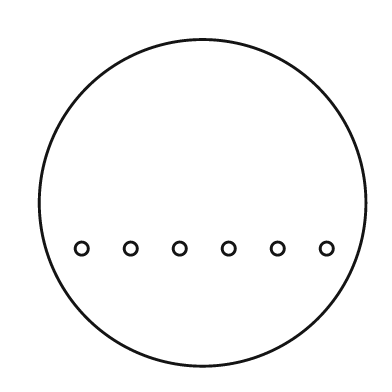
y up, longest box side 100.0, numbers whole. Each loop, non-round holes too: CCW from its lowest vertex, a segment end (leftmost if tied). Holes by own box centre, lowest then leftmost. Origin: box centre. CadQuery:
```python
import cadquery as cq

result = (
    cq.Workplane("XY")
    .moveTo(0.0, 0.0)
    .circle(50.0)
    .moveTo(-37.0, -14.0)
    .circle(2.0)
    .moveTo(-22.0, -14.0)
    .circle(2.0)
    .moveTo(-7.0, -14.0)
    .circle(2.0)
    .moveTo(8.0, -14.0)
    .circle(2.0)
    .moveTo(23.0, -14.0)
    .circle(2.0)
    .moveTo(38.0, -14.0)
    .circle(2.0)
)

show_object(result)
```